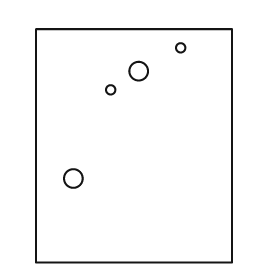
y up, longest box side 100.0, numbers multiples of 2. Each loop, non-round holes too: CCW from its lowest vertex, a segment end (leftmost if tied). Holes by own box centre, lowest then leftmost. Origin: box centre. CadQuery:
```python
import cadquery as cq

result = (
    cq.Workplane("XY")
    .moveTo(-42.0, -50.0)
    .lineTo(42.0, -50.0)
    .lineTo(42.0, 50.0)
    .lineTo(-42.0, 50.0)
    .close()
    .moveTo(-26.0, -14.0)
    .circle(4.0)
    .moveTo(-10.0, 24.0)
    .circle(2.0)
    .moveTo(2.0, 32.0)
    .circle(4.0)
    .moveTo(20.0, 42.0)
    .circle(2.0)
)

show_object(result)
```